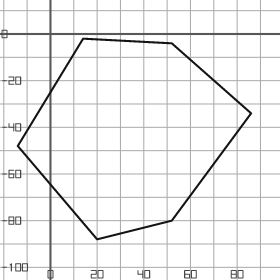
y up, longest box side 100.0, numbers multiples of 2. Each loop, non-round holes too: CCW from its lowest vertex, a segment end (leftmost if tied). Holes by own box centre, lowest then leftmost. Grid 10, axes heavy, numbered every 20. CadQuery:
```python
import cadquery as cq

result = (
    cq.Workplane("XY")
    .moveTo(20.0, -88.0)
    .lineTo(52.0, -80.0)
    .lineTo(86.0, -34.0)
    .lineTo(52.0, -4.0)
    .lineTo(14.0, -2.0)
    .lineTo(-14.0, -48.0)
    .close()
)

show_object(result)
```